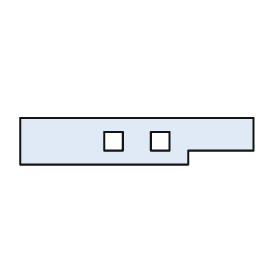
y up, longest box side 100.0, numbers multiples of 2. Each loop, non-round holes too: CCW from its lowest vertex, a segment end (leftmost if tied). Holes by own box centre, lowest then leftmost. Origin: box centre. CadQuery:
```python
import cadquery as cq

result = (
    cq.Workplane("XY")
    .moveTo(-50.0, -10.0)
    .lineTo(22.0, -10.0)
    .lineTo(22.0, -4.0)
    .lineTo(50.0, -4.0)
    .lineTo(50.0, 10.0)
    .lineTo(-50.0, 10.0)
    .close()
    .moveTo(-14.0, -4.0)
    .lineTo(-6.0, -4.0)
    .lineTo(-6.0, 4.0)
    .lineTo(-14.0, 4.0)
    .close()
    .moveTo(6.0, -4.0)
    .lineTo(14.0, -4.0)
    .lineTo(14.0, 4.0)
    .lineTo(6.0, 4.0)
    .close()
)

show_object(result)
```